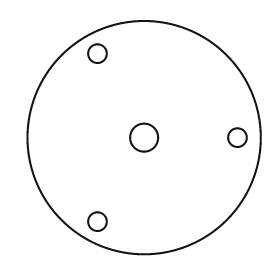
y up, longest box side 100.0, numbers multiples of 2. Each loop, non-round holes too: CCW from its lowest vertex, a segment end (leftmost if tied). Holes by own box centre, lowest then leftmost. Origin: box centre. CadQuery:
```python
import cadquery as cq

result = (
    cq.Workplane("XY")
    .moveTo(0.0, 0.0)
    .circle(50.0)
    .moveTo(-20.0, -36.0)
    .circle(4.0)
    .moveTo(0.0, 0.0)
    .circle(6.0)
    .moveTo(40.0, 0.0)
    .circle(4.0)
    .moveTo(-20.0, 36.0)
    .circle(4.0)
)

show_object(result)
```